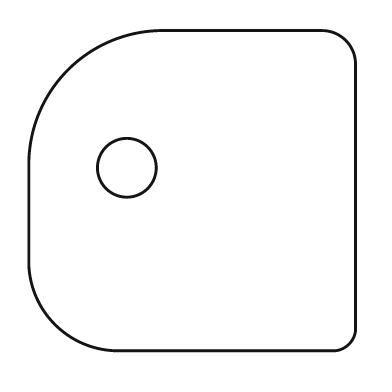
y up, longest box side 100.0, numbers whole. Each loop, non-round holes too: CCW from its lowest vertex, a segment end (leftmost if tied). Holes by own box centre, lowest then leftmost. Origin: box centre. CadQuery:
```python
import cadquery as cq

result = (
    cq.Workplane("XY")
    .moveTo(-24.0, -49.0)
    .lineTo(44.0, -49.0)
    .threePointArc((48.0, -47.0), (50.0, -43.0))
    .lineTo(50.0, 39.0)
    .threePointArc((47.0, 46.0), (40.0, 49.0))
    .lineTo(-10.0, 49.0)
    .threePointArc((-38.0, 37.0), (-50.0, 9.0))
    .lineTo(-50.0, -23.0)
    .threePointArc((-42.0, -41.0), (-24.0, -49.0))
    .close()
    .moveTo(-20.0, 7.0)
    .circle(9.0)
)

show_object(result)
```